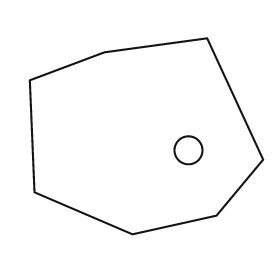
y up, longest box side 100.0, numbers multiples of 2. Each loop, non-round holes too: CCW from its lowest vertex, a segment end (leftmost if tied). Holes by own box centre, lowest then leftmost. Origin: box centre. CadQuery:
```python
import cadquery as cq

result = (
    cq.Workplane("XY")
    .moveTo(-6.0, -42.0)
    .lineTo(30.0, -34.0)
    .lineTo(50.0, -10.0)
    .lineTo(26.0, 42.0)
    .lineTo(-18.0, 36.0)
    .lineTo(-50.0, 24.0)
    .lineTo(-48.0, -24.0)
    .close()
    .moveTo(18.0, -6.0)
    .circle(6.0)
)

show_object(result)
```